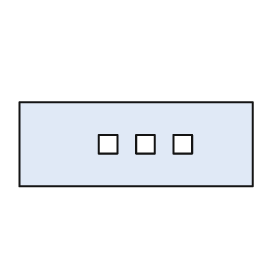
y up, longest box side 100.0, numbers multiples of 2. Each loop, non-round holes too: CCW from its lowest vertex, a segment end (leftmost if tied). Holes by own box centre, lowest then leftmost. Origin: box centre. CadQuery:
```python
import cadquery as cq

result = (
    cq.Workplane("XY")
    .moveTo(-50.0, -18.0)
    .lineTo(50.0, -18.0)
    .lineTo(50.0, 18.0)
    .lineTo(-50.0, 18.0)
    .close()
    .moveTo(-16.0, -4.0)
    .lineTo(-8.0, -4.0)
    .lineTo(-8.0, 4.0)
    .lineTo(-16.0, 4.0)
    .close()
    .moveTo(0.0, -4.0)
    .lineTo(8.0, -4.0)
    .lineTo(8.0, 4.0)
    .lineTo(0.0, 4.0)
    .close()
    .moveTo(16.0, -4.0)
    .lineTo(24.0, -4.0)
    .lineTo(24.0, 4.0)
    .lineTo(16.0, 4.0)
    .close()
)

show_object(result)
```